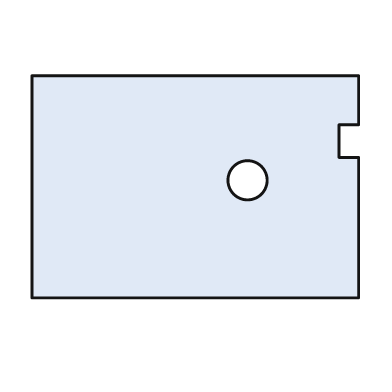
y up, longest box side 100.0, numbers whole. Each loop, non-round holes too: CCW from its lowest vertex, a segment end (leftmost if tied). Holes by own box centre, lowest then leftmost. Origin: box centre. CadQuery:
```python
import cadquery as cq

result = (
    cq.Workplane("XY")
    .moveTo(-50.0, -34.0)
    .lineTo(50.0, -34.0)
    .lineTo(50.0, 9.0)
    .lineTo(44.0, 9.0)
    .lineTo(44.0, 19.0)
    .lineTo(50.0, 19.0)
    .lineTo(50.0, 34.0)
    .lineTo(-50.0, 34.0)
    .close()
    .moveTo(16.0, 2.0)
    .circle(6.0)
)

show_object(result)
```